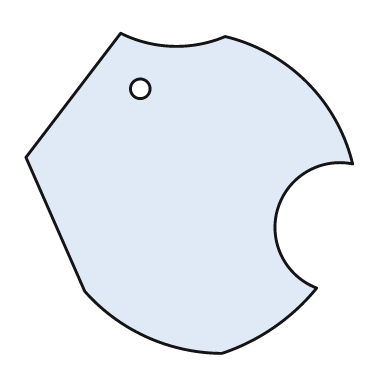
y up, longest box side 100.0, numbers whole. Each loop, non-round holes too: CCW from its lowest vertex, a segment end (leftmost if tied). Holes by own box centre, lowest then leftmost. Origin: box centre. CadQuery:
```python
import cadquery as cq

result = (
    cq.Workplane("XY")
    .moveTo(10.0, -49.0)
    .threePointArc((26.0, -41.0), (39.0, -29.0))
    .threePointArc((27.0, -5.0), (50.0, 9.0))
    .threePointArc((36.0, 34.0), (11.0, 48.0))
    .threePointArc((-5.0, 45.0), (-21.0, 49.0))
    .lineTo(-50.0, 11.0)
    .lineTo(-32.0, -30.0)
    .threePointArc((-13.0, -44.0), (10.0, -49.0))
    .close()
    .moveTo(-15.0, 32.0)
    .circle(3.0)
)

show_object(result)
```